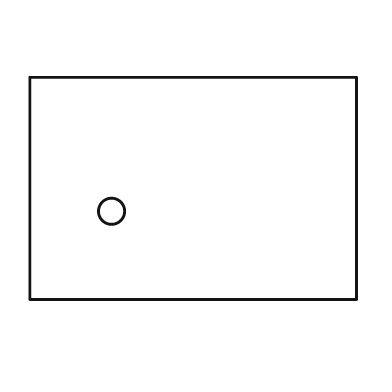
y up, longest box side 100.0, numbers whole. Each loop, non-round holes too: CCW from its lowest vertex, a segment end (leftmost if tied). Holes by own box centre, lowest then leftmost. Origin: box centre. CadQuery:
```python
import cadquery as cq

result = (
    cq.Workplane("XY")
    .moveTo(-50.0, -34.0)
    .lineTo(50.0, -34.0)
    .lineTo(50.0, 34.0)
    .lineTo(-50.0, 34.0)
    .close()
    .moveTo(-25.0, -7.0)
    .circle(4.0)
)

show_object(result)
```